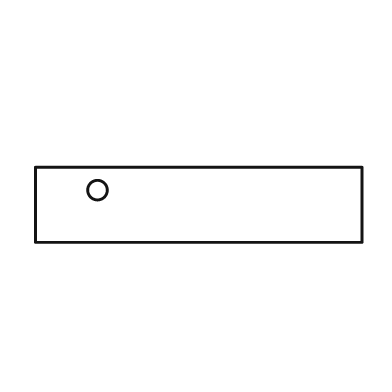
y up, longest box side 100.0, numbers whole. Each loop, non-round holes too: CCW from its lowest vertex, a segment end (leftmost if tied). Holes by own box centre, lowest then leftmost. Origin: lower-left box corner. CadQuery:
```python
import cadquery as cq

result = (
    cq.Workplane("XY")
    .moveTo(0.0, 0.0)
    .lineTo(100.0, 0.0)
    .lineTo(100.0, 23.0)
    .lineTo(0.0, 23.0)
    .close()
    .moveTo(19.0, 16.0)
    .circle(3.0)
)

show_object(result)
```